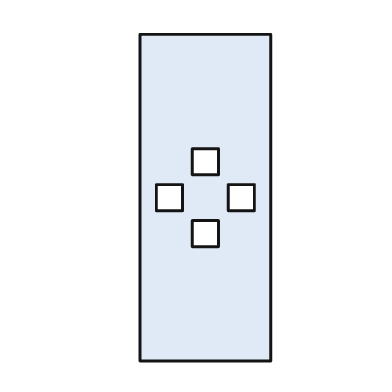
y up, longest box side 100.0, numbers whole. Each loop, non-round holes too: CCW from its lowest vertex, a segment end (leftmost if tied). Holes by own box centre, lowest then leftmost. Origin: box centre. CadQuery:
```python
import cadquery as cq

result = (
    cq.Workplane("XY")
    .moveTo(-20.0, -50.0)
    .lineTo(20.0, -50.0)
    .lineTo(20.0, 50.0)
    .lineTo(-20.0, 50.0)
    .close()
    .moveTo(-4.0, -15.0)
    .lineTo(4.0, -15.0)
    .lineTo(4.0, -7.0)
    .lineTo(-4.0, -7.0)
    .close()
    .moveTo(-15.0, -4.0)
    .lineTo(-7.0, -4.0)
    .lineTo(-7.0, 4.0)
    .lineTo(-15.0, 4.0)
    .close()
    .moveTo(7.0, -4.0)
    .lineTo(15.0, -4.0)
    .lineTo(15.0, 4.0)
    .lineTo(7.0, 4.0)
    .close()
    .moveTo(-4.0, 7.0)
    .lineTo(4.0, 7.0)
    .lineTo(4.0, 15.0)
    .lineTo(-4.0, 15.0)
    .close()
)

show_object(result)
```